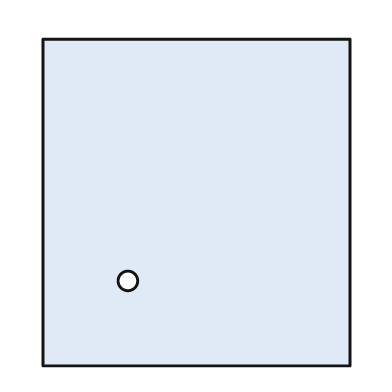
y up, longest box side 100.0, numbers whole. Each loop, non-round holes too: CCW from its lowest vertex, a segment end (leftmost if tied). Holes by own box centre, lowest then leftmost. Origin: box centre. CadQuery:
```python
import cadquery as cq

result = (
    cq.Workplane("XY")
    .moveTo(-47.0, -50.0)
    .lineTo(47.0, -50.0)
    .lineTo(47.0, 50.0)
    .lineTo(-47.0, 50.0)
    .close()
    .moveTo(-21.0, -24.0)
    .circle(3.0)
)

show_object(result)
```